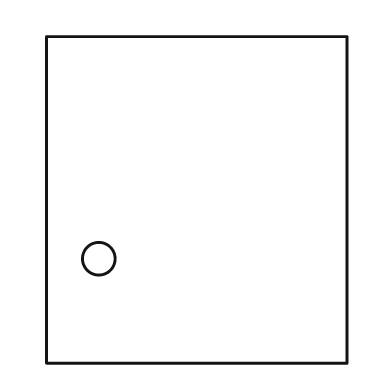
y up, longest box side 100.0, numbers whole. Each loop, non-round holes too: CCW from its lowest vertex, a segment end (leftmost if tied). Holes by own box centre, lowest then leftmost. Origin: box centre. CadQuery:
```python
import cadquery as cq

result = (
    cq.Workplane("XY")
    .moveTo(-46.0, -50.0)
    .lineTo(46.0, -50.0)
    .lineTo(46.0, 50.0)
    .lineTo(-46.0, 50.0)
    .close()
    .moveTo(-30.0, -18.0)
    .circle(5.0)
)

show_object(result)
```